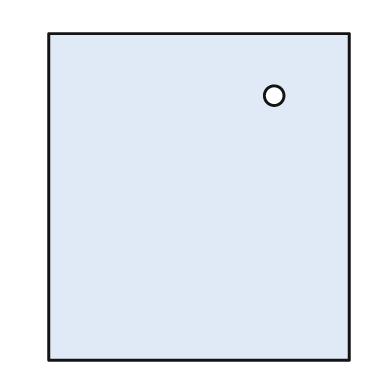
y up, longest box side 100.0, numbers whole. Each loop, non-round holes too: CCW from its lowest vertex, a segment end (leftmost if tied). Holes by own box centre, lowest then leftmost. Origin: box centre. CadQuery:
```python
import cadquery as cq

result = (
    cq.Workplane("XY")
    .moveTo(-46.0, -50.0)
    .lineTo(46.0, -50.0)
    .lineTo(46.0, 50.0)
    .lineTo(-46.0, 50.0)
    .close()
    .moveTo(23.0, 31.0)
    .circle(3.0)
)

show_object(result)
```